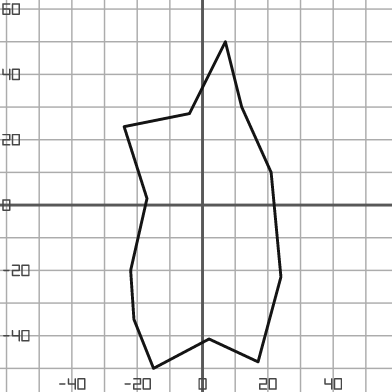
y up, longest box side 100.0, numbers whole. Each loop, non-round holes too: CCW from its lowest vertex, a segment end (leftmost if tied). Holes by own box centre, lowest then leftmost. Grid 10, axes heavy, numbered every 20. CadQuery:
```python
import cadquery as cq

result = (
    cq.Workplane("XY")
    .moveTo(-15.0, -50.0)
    .lineTo(2.0, -41.0)
    .lineTo(17.0, -48.0)
    .lineTo(24.0, -22.0)
    .lineTo(21.0, 10.0)
    .lineTo(12.0, 30.0)
    .lineTo(7.0, 50.0)
    .lineTo(-4.0, 28.0)
    .lineTo(-24.0, 24.0)
    .lineTo(-17.0, 2.0)
    .lineTo(-22.0, -20.0)
    .lineTo(-21.0, -35.0)
    .close()
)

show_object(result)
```